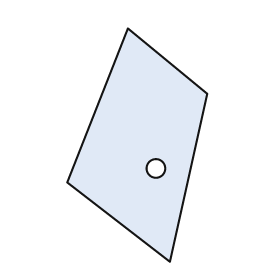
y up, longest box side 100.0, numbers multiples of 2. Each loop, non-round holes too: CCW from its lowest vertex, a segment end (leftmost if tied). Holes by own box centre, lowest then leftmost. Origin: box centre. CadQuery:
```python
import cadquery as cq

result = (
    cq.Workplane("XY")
    .moveTo(14.0, -50.0)
    .lineTo(30.0, 22.0)
    .lineTo(-4.0, 50.0)
    .lineTo(-30.0, -16.0)
    .close()
    .moveTo(8.0, -10.0)
    .circle(4.0)
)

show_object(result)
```